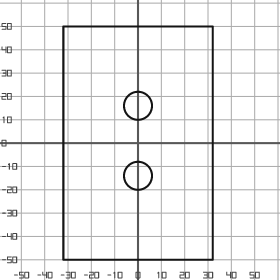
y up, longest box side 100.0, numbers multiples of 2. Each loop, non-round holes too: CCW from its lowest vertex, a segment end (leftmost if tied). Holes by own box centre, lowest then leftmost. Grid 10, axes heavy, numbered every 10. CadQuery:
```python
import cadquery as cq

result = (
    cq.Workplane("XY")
    .moveTo(-32.0, -50.0)
    .lineTo(32.0, -50.0)
    .lineTo(32.0, 50.0)
    .lineTo(-32.0, 50.0)
    .close()
    .moveTo(0.0, -14.0)
    .circle(6.0)
    .moveTo(0.0, 16.0)
    .circle(6.0)
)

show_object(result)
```